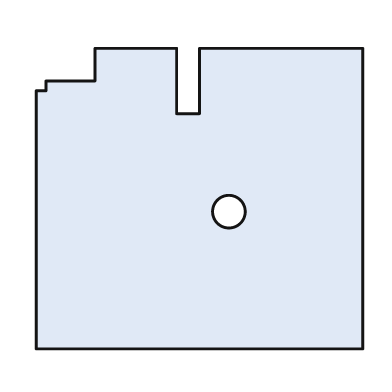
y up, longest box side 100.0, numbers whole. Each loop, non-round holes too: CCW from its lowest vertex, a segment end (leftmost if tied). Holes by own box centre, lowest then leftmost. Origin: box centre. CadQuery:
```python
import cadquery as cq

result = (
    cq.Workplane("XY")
    .moveTo(-50.0, -46.0)
    .lineTo(50.0, -46.0)
    .lineTo(50.0, 46.0)
    .lineTo(0.0, 46.0)
    .lineTo(0.0, 26.0)
    .lineTo(-7.0, 26.0)
    .lineTo(-7.0, 46.0)
    .lineTo(-32.0, 46.0)
    .lineTo(-32.0, 36.0)
    .lineTo(-47.0, 36.0)
    .lineTo(-47.0, 33.0)
    .lineTo(-50.0, 33.0)
    .close()
    .moveTo(9.0, -4.0)
    .circle(5.0)
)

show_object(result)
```